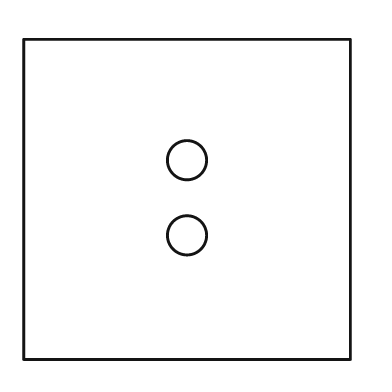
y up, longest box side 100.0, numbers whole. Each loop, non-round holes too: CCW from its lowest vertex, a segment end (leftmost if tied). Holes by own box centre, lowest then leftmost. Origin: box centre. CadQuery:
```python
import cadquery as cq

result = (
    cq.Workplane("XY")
    .moveTo(-50.0, -49.0)
    .lineTo(50.0, -49.0)
    .lineTo(50.0, 49.0)
    .lineTo(-50.0, 49.0)
    .close()
    .moveTo(0.0, -11.0)
    .circle(6.0)
    .moveTo(0.0, 12.0)
    .circle(6.0)
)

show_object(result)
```